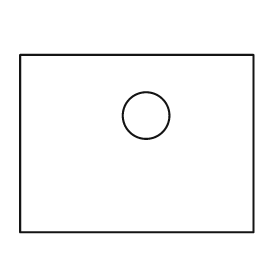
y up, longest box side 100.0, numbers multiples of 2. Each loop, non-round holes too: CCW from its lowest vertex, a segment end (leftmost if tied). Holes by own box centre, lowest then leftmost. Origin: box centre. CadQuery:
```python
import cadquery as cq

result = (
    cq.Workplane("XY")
    .moveTo(-50.0, -38.0)
    .lineTo(50.0, -38.0)
    .lineTo(50.0, 38.0)
    .lineTo(-50.0, 38.0)
    .close()
    .moveTo(4.0, 12.0)
    .circle(10.0)
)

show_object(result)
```